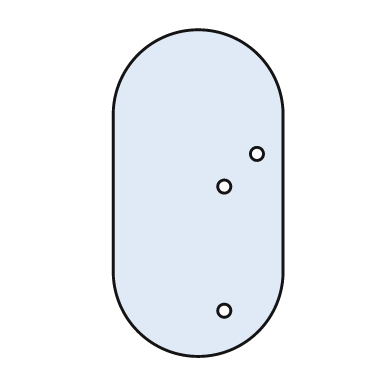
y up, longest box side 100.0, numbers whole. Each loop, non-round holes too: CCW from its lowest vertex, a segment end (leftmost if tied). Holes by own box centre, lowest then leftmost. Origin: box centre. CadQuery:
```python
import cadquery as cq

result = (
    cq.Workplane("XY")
    .moveTo(-26.0, -24.0)
    .threePointArc((0.0, -50.0), (26.0, -24.0))
    .lineTo(26.0, 24.0)
    .threePointArc((0.0, 50.0), (-26.0, 24.0))
    .close()
    .moveTo(8.0, -36.0)
    .circle(2.0)
    .moveTo(8.0, 2.0)
    .circle(2.0)
    .moveTo(18.0, 12.0)
    .circle(2.0)
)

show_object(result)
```